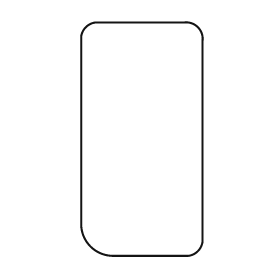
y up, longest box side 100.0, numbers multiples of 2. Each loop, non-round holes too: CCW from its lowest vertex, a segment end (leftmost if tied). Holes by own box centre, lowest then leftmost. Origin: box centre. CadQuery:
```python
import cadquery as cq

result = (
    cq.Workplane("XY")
    .moveTo(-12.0, -50.0)
    .lineTo(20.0, -50.0)
    .threePointArc((24.0, -48.0), (26.0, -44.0))
    .lineTo(26.0, 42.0)
    .threePointArc((24.0, 48.0), (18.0, 50.0))
    .lineTo(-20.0, 50.0)
    .threePointArc((-24.0, 48.0), (-26.0, 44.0))
    .lineTo(-26.0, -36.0)
    .threePointArc((-22.0, -46.0), (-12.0, -50.0))
    .close()
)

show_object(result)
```